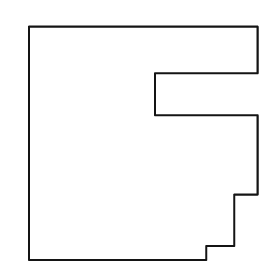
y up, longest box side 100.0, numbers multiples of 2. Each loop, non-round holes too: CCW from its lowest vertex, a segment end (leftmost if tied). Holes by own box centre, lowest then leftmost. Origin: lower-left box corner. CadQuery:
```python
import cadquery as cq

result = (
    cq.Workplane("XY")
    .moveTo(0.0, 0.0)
    .lineTo(76.0, 0.0)
    .lineTo(76.0, 6.0)
    .lineTo(88.0, 6.0)
    .lineTo(88.0, 28.0)
    .lineTo(98.0, 28.0)
    .lineTo(98.0, 62.0)
    .lineTo(54.0, 62.0)
    .lineTo(54.0, 80.0)
    .lineTo(98.0, 80.0)
    .lineTo(98.0, 100.0)
    .lineTo(0.0, 100.0)
    .close()
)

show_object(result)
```